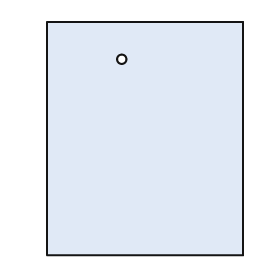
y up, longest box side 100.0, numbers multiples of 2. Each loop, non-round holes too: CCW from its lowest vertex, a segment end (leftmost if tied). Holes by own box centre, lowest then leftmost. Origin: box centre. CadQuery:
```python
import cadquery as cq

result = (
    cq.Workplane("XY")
    .moveTo(-42.0, -50.0)
    .lineTo(42.0, -50.0)
    .lineTo(42.0, 50.0)
    .lineTo(-42.0, 50.0)
    .close()
    .moveTo(-10.0, 34.0)
    .circle(2.0)
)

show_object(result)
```